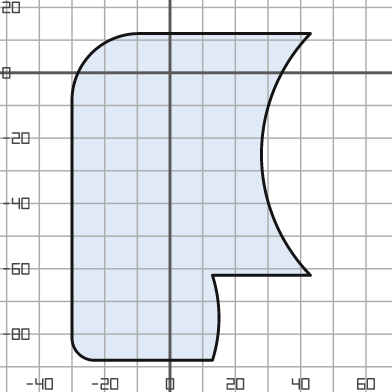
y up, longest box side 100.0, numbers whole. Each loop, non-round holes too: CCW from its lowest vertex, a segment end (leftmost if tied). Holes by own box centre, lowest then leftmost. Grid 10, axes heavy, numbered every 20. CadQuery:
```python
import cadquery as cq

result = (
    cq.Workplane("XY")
    .moveTo(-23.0, -88.0)
    .lineTo(13.0, -88.0)
    .threePointArc((15.0, -75.0), (13.0, -62.0))
    .lineTo(43.0, -62.0)
    .threePointArc((28.0, -25.0), (43.0, 12.0))
    .lineTo(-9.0, 12.0)
    .threePointArc((-24.0, 6.0), (-30.0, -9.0))
    .lineTo(-30.0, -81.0)
    .threePointArc((-28.0, -86.0), (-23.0, -88.0))
    .close()
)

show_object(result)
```